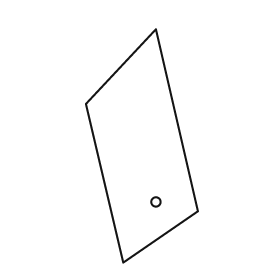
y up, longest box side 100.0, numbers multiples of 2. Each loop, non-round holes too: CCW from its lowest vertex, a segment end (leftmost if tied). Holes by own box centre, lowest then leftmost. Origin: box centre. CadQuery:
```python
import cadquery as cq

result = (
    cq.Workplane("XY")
    .moveTo(-8.0, -50.0)
    .lineTo(24.0, -28.0)
    .lineTo(6.0, 50.0)
    .lineTo(-24.0, 18.0)
    .close()
    .moveTo(6.0, -24.0)
    .circle(2.0)
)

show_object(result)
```